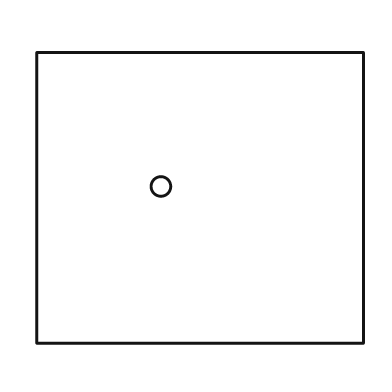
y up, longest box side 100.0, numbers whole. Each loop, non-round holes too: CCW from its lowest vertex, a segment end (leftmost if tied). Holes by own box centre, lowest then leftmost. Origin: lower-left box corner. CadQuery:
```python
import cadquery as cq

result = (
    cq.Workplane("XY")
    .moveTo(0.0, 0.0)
    .lineTo(100.0, 0.0)
    .lineTo(100.0, 89.0)
    .lineTo(0.0, 89.0)
    .close()
    .moveTo(38.0, 48.0)
    .circle(3.0)
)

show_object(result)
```